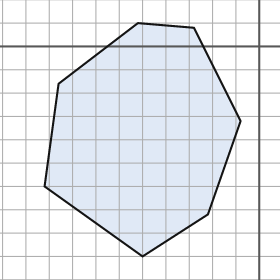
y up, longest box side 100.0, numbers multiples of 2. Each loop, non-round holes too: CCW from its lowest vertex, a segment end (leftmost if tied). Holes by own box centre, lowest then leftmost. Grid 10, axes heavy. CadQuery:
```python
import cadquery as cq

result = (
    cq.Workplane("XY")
    .moveTo(-50.0, -90.0)
    .lineTo(-22.0, -72.0)
    .lineTo(-8.0, -32.0)
    .lineTo(-28.0, 8.0)
    .lineTo(-52.0, 10.0)
    .lineTo(-86.0, -16.0)
    .lineTo(-92.0, -60.0)
    .close()
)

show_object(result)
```